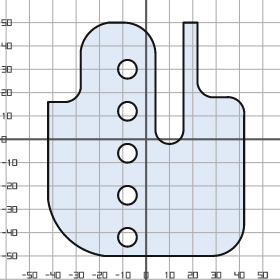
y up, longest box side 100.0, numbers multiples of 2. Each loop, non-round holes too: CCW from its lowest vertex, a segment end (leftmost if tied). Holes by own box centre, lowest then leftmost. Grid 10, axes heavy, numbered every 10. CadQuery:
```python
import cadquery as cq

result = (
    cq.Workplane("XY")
    .moveTo(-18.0, -50.0)
    .lineTo(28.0, -50.0)
    .threePointArc((38.0, -46.0), (42.0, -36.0))
    .lineTo(42.0, 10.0)
    .threePointArc((40.0, 16.0), (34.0, 18.0))
    .lineTo(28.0, 18.0)
    .threePointArc((24.0, 20.0), (22.0, 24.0))
    .lineTo(22.0, 50.0)
    .lineTo(16.0, 50.0)
    .lineTo(16.0, 4.0)
    .threePointArc((10.0, -2.0), (4.0, 4.0))
    .lineTo(4.0, 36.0)
    .threePointArc((0.0, 46.0), (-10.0, 50.0))
    .lineTo(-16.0, 50.0)
    .threePointArc((-24.0, 46.0), (-28.0, 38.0))
    .lineTo(-28.0, 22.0)
    .threePointArc((-30.0, 18.0), (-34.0, 16.0))
    .lineTo(-42.0, 16.0)
    .lineTo(-42.0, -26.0)
    .threePointArc((-34.0, -42.0), (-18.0, -50.0))
    .close()
    .moveTo(-8.0, -42.0)
    .circle(4.0)
    .moveTo(-8.0, -24.0)
    .circle(4.0)
    .moveTo(-8.0, -6.0)
    .circle(4.0)
    .moveTo(-8.0, 12.0)
    .circle(4.0)
    .moveTo(-8.0, 30.0)
    .circle(4.0)
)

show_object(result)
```